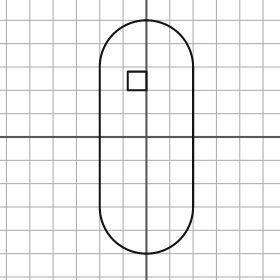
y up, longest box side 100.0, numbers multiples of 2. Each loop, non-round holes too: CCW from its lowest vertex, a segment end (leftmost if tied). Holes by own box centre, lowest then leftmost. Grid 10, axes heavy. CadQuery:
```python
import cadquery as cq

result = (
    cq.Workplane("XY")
    .moveTo(-20.0, -30.0)
    .threePointArc((0.0, -50.0), (20.0, -30.0))
    .lineTo(20.0, 30.0)
    .threePointArc((0.0, 50.0), (-20.0, 30.0))
    .close()
    .moveTo(-8.0, 20.0)
    .lineTo(0.0, 20.0)
    .lineTo(0.0, 28.0)
    .lineTo(-8.0, 28.0)
    .close()
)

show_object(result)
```